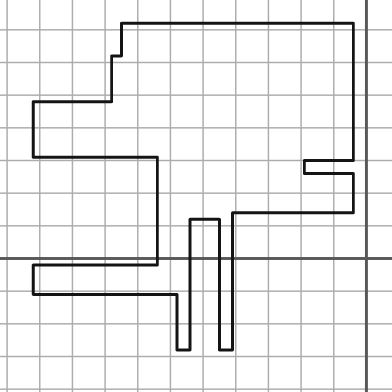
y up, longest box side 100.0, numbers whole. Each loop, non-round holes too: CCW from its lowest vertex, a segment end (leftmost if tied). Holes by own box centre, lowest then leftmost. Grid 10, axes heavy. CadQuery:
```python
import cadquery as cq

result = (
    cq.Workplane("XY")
    .moveTo(-58.0, -28.0)
    .lineTo(-54.0, -28.0)
    .lineTo(-54.0, 12.0)
    .lineTo(-45.0, 12.0)
    .lineTo(-45.0, -28.0)
    .lineTo(-41.0, -28.0)
    .lineTo(-41.0, 14.0)
    .lineTo(-4.0, 14.0)
    .lineTo(-4.0, 26.0)
    .lineTo(-19.0, 26.0)
    .lineTo(-19.0, 30.0)
    .lineTo(-4.0, 30.0)
    .lineTo(-4.0, 72.0)
    .lineTo(-75.0, 72.0)
    .lineTo(-75.0, 62.0)
    .lineTo(-78.0, 62.0)
    .lineTo(-78.0, 48.0)
    .lineTo(-102.0, 48.0)
    .lineTo(-102.0, 31.0)
    .lineTo(-64.0, 31.0)
    .lineTo(-64.0, -2.0)
    .lineTo(-102.0, -2.0)
    .lineTo(-102.0, -11.0)
    .lineTo(-58.0, -11.0)
    .close()
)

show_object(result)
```